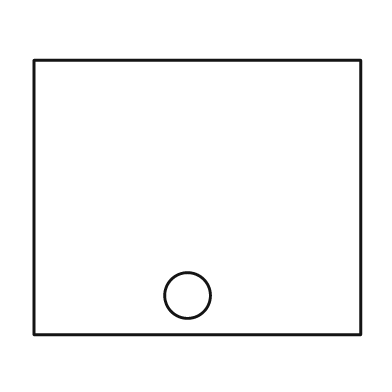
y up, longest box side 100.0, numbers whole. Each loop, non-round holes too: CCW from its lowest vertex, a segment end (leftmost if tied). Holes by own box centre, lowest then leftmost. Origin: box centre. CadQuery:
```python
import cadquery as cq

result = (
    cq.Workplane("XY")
    .moveTo(-50.0, -42.0)
    .lineTo(50.0, -42.0)
    .lineTo(50.0, 42.0)
    .lineTo(-50.0, 42.0)
    .close()
    .moveTo(-3.0, -30.0)
    .circle(7.0)
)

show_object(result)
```